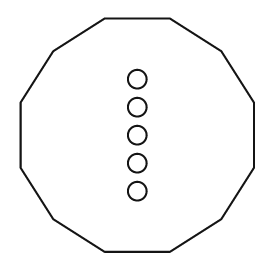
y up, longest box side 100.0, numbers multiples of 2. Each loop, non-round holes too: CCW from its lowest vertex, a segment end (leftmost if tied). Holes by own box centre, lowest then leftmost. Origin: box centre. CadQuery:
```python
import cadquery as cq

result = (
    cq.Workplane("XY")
    .moveTo(-14.0, -50.0)
    .lineTo(14.0, -50.0)
    .lineTo(36.0, -36.0)
    .lineTo(50.0, -14.0)
    .lineTo(50.0, 14.0)
    .lineTo(36.0, 36.0)
    .lineTo(14.0, 50.0)
    .lineTo(-14.0, 50.0)
    .lineTo(-36.0, 36.0)
    .lineTo(-50.0, 14.0)
    .lineTo(-50.0, -14.0)
    .lineTo(-36.0, -36.0)
    .close()
    .moveTo(0.0, -24.0)
    .circle(4.0)
    .moveTo(0.0, -12.0)
    .circle(4.0)
    .moveTo(0.0, 0.0)
    .circle(4.0)
    .moveTo(0.0, 12.0)
    .circle(4.0)
    .moveTo(0.0, 24.0)
    .circle(4.0)
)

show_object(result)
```